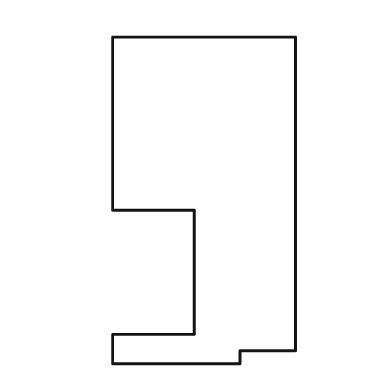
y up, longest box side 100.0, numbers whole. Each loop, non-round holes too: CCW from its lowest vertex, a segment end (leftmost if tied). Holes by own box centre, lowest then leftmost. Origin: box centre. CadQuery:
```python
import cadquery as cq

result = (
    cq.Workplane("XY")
    .moveTo(-28.0, -50.0)
    .lineTo(11.0, -50.0)
    .lineTo(11.0, -46.0)
    .lineTo(28.0, -46.0)
    .lineTo(28.0, 50.0)
    .lineTo(-28.0, 50.0)
    .lineTo(-28.0, -3.0)
    .lineTo(-3.0, -3.0)
    .lineTo(-3.0, -41.0)
    .lineTo(-28.0, -41.0)
    .close()
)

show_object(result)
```